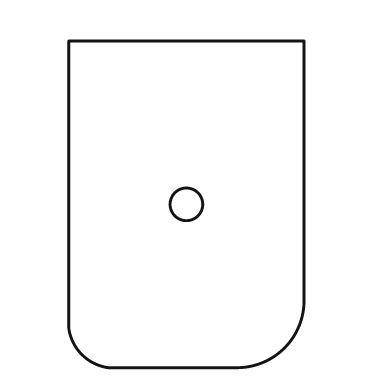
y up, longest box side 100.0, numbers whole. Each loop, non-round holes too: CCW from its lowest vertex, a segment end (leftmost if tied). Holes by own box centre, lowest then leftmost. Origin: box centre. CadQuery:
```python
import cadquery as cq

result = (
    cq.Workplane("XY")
    .moveTo(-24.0, -50.0)
    .lineTo(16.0, -50.0)
    .threePointArc((30.0, -44.0), (36.0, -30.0))
    .lineTo(36.0, 50.0)
    .lineTo(-36.0, 50.0)
    .lineTo(-36.0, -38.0)
    .threePointArc((-32.0, -46.0), (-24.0, -50.0))
    .close()
    .moveTo(0.0, 0.0)
    .circle(5.0)
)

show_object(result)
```